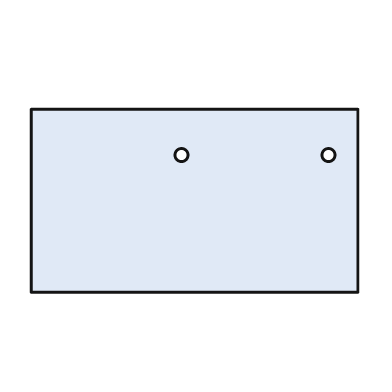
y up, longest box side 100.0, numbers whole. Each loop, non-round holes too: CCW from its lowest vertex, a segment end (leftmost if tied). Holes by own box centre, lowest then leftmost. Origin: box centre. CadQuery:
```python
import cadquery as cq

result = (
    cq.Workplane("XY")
    .moveTo(-50.0, -28.0)
    .lineTo(50.0, -28.0)
    .lineTo(50.0, 28.0)
    .lineTo(-50.0, 28.0)
    .close()
    .moveTo(-4.0, 14.0)
    .circle(2.0)
    .moveTo(41.0, 14.0)
    .circle(2.0)
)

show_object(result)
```